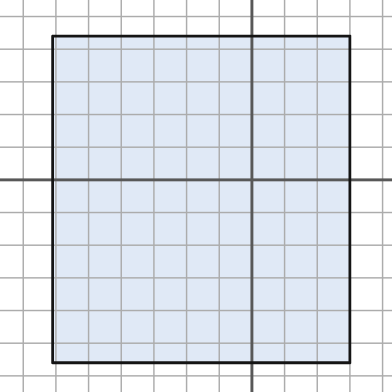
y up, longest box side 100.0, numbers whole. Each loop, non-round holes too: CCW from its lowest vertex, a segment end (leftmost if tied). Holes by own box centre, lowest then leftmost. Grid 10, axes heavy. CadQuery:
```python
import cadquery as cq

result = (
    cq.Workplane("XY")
    .moveTo(-61.0, -56.0)
    .lineTo(30.0, -56.0)
    .lineTo(30.0, 44.0)
    .lineTo(-61.0, 44.0)
    .close()
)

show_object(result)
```